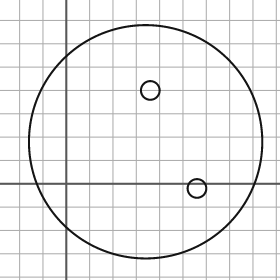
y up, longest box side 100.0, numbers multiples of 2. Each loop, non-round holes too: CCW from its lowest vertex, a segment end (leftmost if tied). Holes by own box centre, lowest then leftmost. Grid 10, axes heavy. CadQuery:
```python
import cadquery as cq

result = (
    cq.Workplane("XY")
    .moveTo(34.0, 18.0)
    .circle(50.0)
    .moveTo(56.0, -2.0)
    .circle(4.0)
    .moveTo(36.0, 40.0)
    .circle(4.0)
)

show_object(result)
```